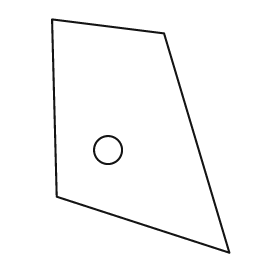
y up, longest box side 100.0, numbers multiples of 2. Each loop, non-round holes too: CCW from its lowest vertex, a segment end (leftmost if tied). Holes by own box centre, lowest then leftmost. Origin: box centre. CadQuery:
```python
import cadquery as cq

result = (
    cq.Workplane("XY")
    .moveTo(38.0, -50.0)
    .lineTo(10.0, 44.0)
    .lineTo(-38.0, 50.0)
    .lineTo(-36.0, -26.0)
    .close()
    .moveTo(-14.0, -6.0)
    .circle(6.0)
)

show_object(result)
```